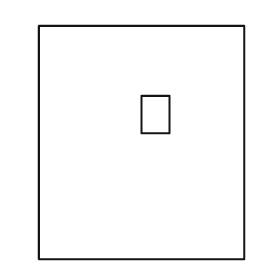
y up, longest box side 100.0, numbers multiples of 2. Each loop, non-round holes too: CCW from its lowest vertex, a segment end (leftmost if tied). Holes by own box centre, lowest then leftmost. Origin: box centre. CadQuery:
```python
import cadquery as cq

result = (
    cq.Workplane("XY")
    .moveTo(-44.0, -50.0)
    .lineTo(44.0, -50.0)
    .lineTo(44.0, 50.0)
    .lineTo(-44.0, 50.0)
    .close()
    .moveTo(0.0, 4.0)
    .lineTo(12.0, 4.0)
    .lineTo(12.0, 20.0)
    .lineTo(0.0, 20.0)
    .close()
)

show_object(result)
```